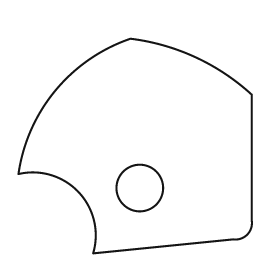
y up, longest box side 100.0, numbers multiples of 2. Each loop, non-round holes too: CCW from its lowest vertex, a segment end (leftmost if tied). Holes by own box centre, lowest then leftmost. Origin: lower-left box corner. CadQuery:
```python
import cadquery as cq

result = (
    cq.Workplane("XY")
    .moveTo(32.0, 0.0)
    .lineTo(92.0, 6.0)
    .threePointArc((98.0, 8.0), (100.0, 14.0))
    .lineTo(100.0, 68.0)
    .threePointArc((76.0, 84.0), (48.0, 92.0))
    .threePointArc((16.0, 70.0), (0.0, 34.0))
    .threePointArc((26.0, 26.0), (32.0, 0.0))
    .close()
    .moveTo(52.0, 28.0)
    .circle(10.0)
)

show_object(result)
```